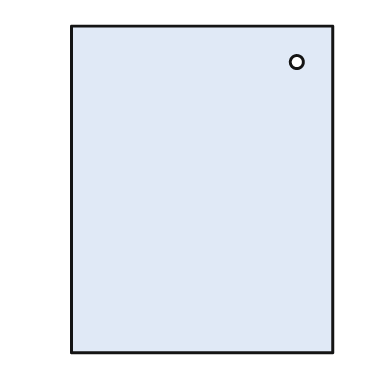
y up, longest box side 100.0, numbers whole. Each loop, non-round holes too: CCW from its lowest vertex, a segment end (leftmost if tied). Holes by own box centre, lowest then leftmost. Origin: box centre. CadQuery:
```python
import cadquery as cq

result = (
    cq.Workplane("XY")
    .moveTo(-40.0, -50.0)
    .lineTo(40.0, -50.0)
    .lineTo(40.0, 50.0)
    .lineTo(-40.0, 50.0)
    .close()
    .moveTo(29.0, 39.0)
    .circle(2.0)
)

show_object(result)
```